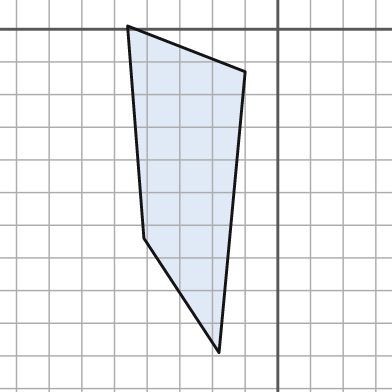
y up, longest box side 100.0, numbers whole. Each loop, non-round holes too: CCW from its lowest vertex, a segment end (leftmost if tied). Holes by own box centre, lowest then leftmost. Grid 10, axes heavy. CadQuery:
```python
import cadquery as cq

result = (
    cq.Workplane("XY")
    .moveTo(-18.0, -99.0)
    .lineTo(-10.0, -13.0)
    .lineTo(-46.0, 1.0)
    .lineTo(-41.0, -64.0)
    .close()
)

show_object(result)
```